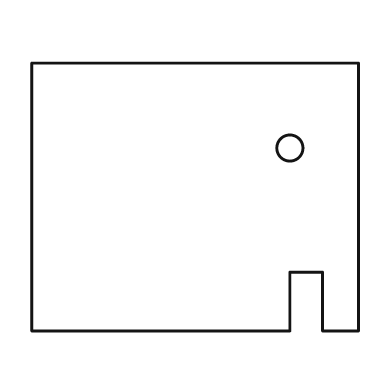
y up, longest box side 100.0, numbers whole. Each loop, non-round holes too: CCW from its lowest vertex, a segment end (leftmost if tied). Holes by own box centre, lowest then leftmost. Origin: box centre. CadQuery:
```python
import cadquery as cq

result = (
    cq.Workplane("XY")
    .moveTo(-50.0, -41.0)
    .lineTo(29.0, -41.0)
    .lineTo(29.0, -23.0)
    .lineTo(39.0, -23.0)
    .lineTo(39.0, -41.0)
    .lineTo(50.0, -41.0)
    .lineTo(50.0, 41.0)
    .lineTo(-50.0, 41.0)
    .close()
    .moveTo(29.0, 15.0)
    .circle(4.0)
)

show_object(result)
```